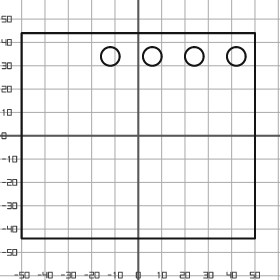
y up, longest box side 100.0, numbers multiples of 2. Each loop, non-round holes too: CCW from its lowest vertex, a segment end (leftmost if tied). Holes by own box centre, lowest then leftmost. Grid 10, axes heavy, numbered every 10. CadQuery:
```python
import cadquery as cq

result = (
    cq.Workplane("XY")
    .moveTo(-50.0, -44.0)
    .lineTo(50.0, -44.0)
    .lineTo(50.0, 44.0)
    .lineTo(-50.0, 44.0)
    .close()
    .moveTo(-12.0, 34.0)
    .circle(4.0)
    .moveTo(6.0, 34.0)
    .circle(4.0)
    .moveTo(24.0, 34.0)
    .circle(4.0)
    .moveTo(42.0, 34.0)
    .circle(4.0)
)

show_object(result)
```